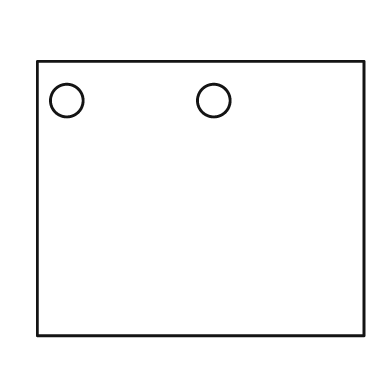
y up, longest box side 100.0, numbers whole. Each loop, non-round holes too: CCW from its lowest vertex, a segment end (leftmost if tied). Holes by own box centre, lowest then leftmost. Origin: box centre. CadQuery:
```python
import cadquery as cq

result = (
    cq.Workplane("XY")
    .moveTo(-50.0, -42.0)
    .lineTo(50.0, -42.0)
    .lineTo(50.0, 42.0)
    .lineTo(-50.0, 42.0)
    .close()
    .moveTo(-41.0, 30.0)
    .circle(5.0)
    .moveTo(4.0, 30.0)
    .circle(5.0)
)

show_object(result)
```